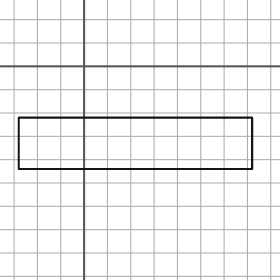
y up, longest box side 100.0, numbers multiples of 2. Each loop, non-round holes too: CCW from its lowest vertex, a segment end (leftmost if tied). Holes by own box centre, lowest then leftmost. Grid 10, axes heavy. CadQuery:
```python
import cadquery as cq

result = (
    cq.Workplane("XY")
    .moveTo(-28.0, -44.0)
    .lineTo(72.0, -44.0)
    .lineTo(72.0, -22.0)
    .lineTo(-28.0, -22.0)
    .close()
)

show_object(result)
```